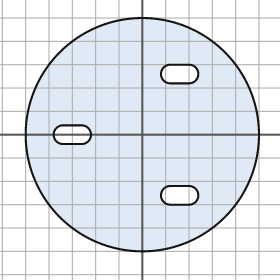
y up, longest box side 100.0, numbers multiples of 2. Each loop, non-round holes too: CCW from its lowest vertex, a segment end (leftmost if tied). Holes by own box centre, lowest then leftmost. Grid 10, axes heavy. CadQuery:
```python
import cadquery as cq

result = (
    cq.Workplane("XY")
    .moveTo(0.0, 0.0)
    .circle(50.0)
    .moveTo(12.0, -30.0)
    .lineTo(20.0, -30.0)
    .threePointArc((24.0, -26.0), (20.0, -22.0))
    .lineTo(12.0, -22.0)
    .threePointArc((8.0, -26.0), (12.0, -30.0))
    .close()
    .moveTo(-34.0, -4.0)
    .lineTo(-26.0, -4.0)
    .threePointArc((-22.0, 0.0), (-26.0, 4.0))
    .lineTo(-34.0, 4.0)
    .threePointArc((-38.0, 0.0), (-34.0, -4.0))
    .close()
    .moveTo(12.0, 22.0)
    .lineTo(20.0, 22.0)
    .threePointArc((24.0, 26.0), (20.0, 30.0))
    .lineTo(12.0, 30.0)
    .threePointArc((8.0, 26.0), (12.0, 22.0))
    .close()
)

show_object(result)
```